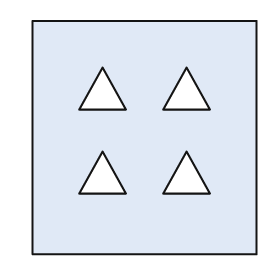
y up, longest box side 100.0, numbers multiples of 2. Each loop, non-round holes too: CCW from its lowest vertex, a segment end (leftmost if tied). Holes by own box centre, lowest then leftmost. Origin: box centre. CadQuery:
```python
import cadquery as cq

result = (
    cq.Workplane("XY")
    .moveTo(-48.0, -50.0)
    .lineTo(48.0, -50.0)
    .lineTo(48.0, 50.0)
    .lineTo(-48.0, 50.0)
    .close()
    .moveTo(-28.0, -24.0)
    .lineTo(-8.0, -24.0)
    .lineTo(-18.0, -6.0)
    .close()
    .moveTo(8.0, -24.0)
    .lineTo(28.0, -24.0)
    .lineTo(18.0, -6.0)
    .close()
    .moveTo(-28.0, 12.0)
    .lineTo(-8.0, 12.0)
    .lineTo(-18.0, 30.0)
    .close()
    .moveTo(8.0, 12.0)
    .lineTo(28.0, 12.0)
    .lineTo(18.0, 30.0)
    .close()
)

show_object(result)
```